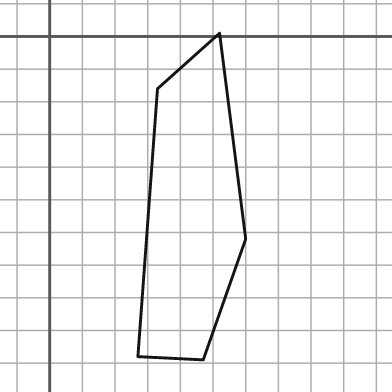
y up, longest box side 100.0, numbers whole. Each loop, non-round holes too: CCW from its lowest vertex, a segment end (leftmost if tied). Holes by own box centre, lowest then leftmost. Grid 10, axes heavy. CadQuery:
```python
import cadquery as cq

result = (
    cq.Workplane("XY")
    .moveTo(47.0, -99.0)
    .lineTo(60.0, -62.0)
    .lineTo(52.0, 1.0)
    .lineTo(33.0, -16.0)
    .lineTo(27.0, -98.0)
    .close()
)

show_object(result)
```